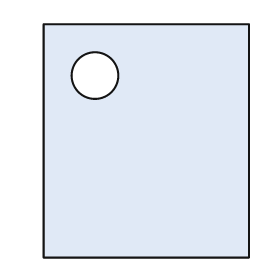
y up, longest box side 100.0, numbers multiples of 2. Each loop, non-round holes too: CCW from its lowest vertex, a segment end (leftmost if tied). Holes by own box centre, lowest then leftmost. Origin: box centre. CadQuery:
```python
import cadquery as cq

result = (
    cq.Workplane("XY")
    .moveTo(-44.0, -50.0)
    .lineTo(44.0, -50.0)
    .lineTo(44.0, 50.0)
    .lineTo(-44.0, 50.0)
    .close()
    .moveTo(-22.0, 28.0)
    .circle(10.0)
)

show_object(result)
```